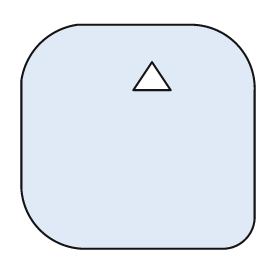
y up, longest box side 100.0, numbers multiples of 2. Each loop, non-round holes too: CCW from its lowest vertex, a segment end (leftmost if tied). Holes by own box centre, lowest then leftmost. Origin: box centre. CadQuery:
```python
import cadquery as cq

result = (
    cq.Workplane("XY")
    .moveTo(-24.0, -48.0)
    .lineTo(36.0, -48.0)
    .threePointArc((46.0, -44.0), (50.0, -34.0))
    .lineTo(50.0, 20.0)
    .threePointArc((42.0, 40.0), (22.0, 48.0))
    .lineTo(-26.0, 48.0)
    .threePointArc((-42.0, 40.0), (-50.0, 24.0))
    .lineTo(-50.0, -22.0)
    .threePointArc((-42.0, -40.0), (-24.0, -48.0))
    .close()
    .moveTo(-2.0, 20.0)
    .lineTo(14.0, 20.0)
    .lineTo(6.0, 32.0)
    .close()
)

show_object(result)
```